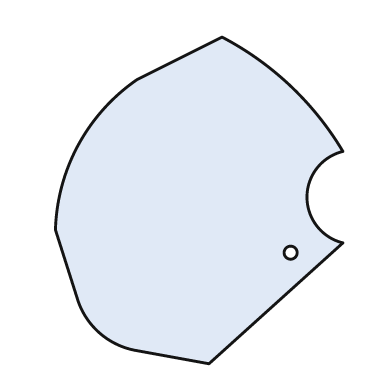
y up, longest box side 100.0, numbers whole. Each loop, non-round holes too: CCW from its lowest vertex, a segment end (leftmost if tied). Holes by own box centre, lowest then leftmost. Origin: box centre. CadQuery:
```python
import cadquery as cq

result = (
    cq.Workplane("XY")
    .moveTo(3.0, -50.0)
    .lineTo(44.0, -13.0)
    .threePointArc((33.0, 1.0), (44.0, 15.0))
    .threePointArc((28.0, 35.0), (7.0, 50.0))
    .lineTo(-19.0, 37.0)
    .threePointArc((-37.0, 17.0), (-44.0, -9.0))
    .lineTo(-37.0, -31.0)
    .threePointArc((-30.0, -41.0), (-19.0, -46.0))
    .close()
    .moveTo(28.0, -16.0)
    .circle(2.0)
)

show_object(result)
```